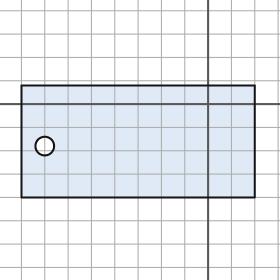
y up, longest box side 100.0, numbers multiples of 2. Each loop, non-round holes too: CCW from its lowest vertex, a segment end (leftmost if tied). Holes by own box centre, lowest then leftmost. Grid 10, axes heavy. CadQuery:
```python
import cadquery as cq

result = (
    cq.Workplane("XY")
    .moveTo(-80.0, -40.0)
    .lineTo(20.0, -40.0)
    .lineTo(20.0, 8.0)
    .lineTo(-80.0, 8.0)
    .close()
    .moveTo(-70.0, -18.0)
    .circle(4.0)
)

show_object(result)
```